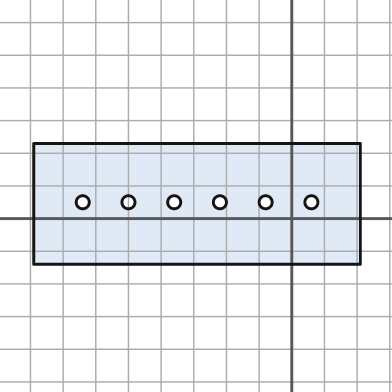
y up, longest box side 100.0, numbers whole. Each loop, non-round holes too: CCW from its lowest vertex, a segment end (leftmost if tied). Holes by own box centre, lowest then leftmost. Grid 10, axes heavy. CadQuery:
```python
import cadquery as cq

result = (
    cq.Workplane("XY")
    .moveTo(-79.0, -14.0)
    .lineTo(21.0, -14.0)
    .lineTo(21.0, 23.0)
    .lineTo(-79.0, 23.0)
    .close()
    .moveTo(-64.0, 5.0)
    .circle(2.0)
    .moveTo(-50.0, 5.0)
    .circle(2.0)
    .moveTo(-36.0, 5.0)
    .circle(2.0)
    .moveTo(-22.0, 5.0)
    .circle(2.0)
    .moveTo(-8.0, 5.0)
    .circle(2.0)
    .moveTo(6.0, 5.0)
    .circle(2.0)
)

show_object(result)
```